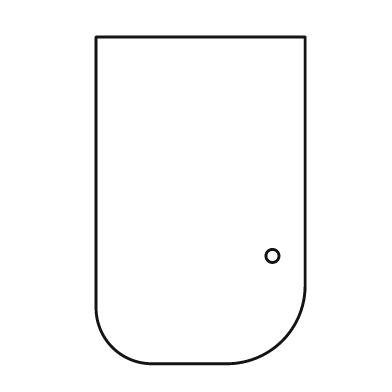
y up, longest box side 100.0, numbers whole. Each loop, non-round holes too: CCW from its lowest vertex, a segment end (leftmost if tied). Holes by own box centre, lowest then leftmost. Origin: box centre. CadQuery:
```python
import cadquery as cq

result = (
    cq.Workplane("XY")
    .moveTo(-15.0, -50.0)
    .lineTo(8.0, -50.0)
    .threePointArc((25.0, -43.0), (32.0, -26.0))
    .lineTo(32.0, 50.0)
    .lineTo(-32.0, 50.0)
    .lineTo(-32.0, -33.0)
    .threePointArc((-27.0, -45.0), (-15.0, -50.0))
    .close()
    .moveTo(22.0, -17.0)
    .circle(2.0)
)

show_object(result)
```